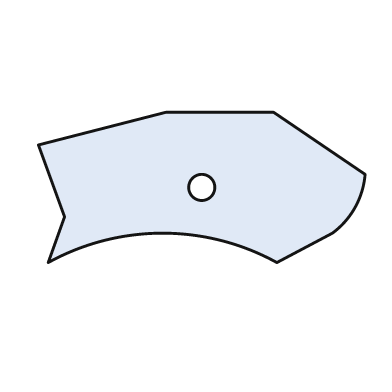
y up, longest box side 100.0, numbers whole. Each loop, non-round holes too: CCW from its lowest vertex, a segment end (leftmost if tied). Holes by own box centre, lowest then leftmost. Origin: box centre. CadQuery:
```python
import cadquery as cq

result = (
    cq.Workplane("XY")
    .moveTo(-47.0, -23.0)
    .threePointArc((-12.0, -14.0), (23.0, -23.0))
    .lineTo(40.0, -14.0)
    .threePointArc((47.0, -6.0), (50.0, 4.0))
    .lineTo(22.0, 23.0)
    .lineTo(-11.0, 23.0)
    .lineTo(-50.0, 13.0)
    .lineTo(-42.0, -9.0)
    .close()
    .moveTo(0.0, 0.0)
    .circle(4.0)
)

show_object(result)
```